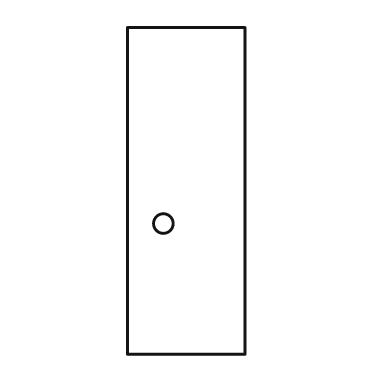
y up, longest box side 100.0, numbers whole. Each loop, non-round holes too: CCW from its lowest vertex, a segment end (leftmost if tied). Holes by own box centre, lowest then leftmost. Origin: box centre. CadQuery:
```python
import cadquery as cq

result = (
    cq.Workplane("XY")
    .moveTo(-18.0, -50.0)
    .lineTo(18.0, -50.0)
    .lineTo(18.0, 50.0)
    .lineTo(-18.0, 50.0)
    .close()
    .moveTo(-7.0, -10.0)
    .circle(3.0)
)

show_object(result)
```